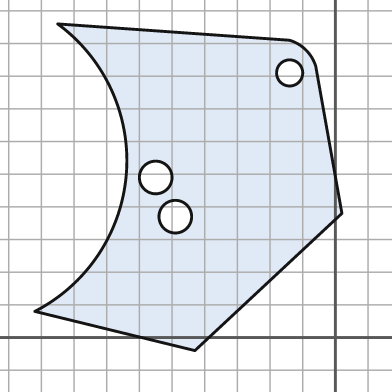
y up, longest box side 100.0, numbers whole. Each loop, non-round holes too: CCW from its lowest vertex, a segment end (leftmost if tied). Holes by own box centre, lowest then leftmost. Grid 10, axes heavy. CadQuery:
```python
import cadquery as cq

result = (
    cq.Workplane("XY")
    .moveTo(-43.0, -4.0)
    .lineTo(2.0, 38.0)
    .lineTo(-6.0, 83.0)
    .threePointArc((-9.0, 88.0), (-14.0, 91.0))
    .lineTo(-85.0, 96.0)
    .threePointArc((-64.0, 50.0), (-92.0, 8.0))
    .close()
    .moveTo(-49.0, 37.0)
    .circle(5.0)
    .moveTo(-55.0, 49.0)
    .circle(5.0)
    .moveTo(-14.0, 81.0)
    .circle(4.0)
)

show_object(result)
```